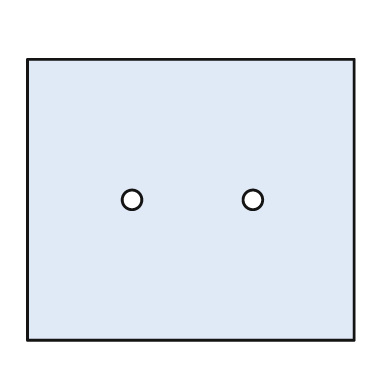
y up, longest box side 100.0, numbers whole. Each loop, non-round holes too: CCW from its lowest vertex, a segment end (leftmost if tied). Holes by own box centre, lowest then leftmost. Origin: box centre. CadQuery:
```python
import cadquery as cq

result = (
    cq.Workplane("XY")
    .moveTo(-50.0, -43.0)
    .lineTo(50.0, -43.0)
    .lineTo(50.0, 43.0)
    .lineTo(-50.0, 43.0)
    .close()
    .moveTo(-18.0, 0.0)
    .circle(3.0)
    .moveTo(19.0, 0.0)
    .circle(3.0)
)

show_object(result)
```